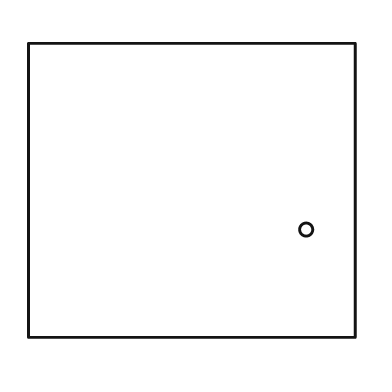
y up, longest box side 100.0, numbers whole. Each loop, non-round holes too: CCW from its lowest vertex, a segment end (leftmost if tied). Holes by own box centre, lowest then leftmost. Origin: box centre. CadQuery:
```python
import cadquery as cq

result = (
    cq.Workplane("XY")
    .moveTo(-50.0, -45.0)
    .lineTo(50.0, -45.0)
    .lineTo(50.0, 45.0)
    .lineTo(-50.0, 45.0)
    .close()
    .moveTo(35.0, -12.0)
    .circle(2.0)
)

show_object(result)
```